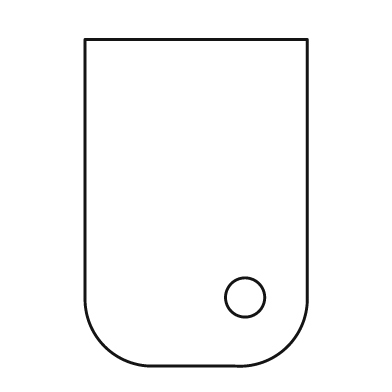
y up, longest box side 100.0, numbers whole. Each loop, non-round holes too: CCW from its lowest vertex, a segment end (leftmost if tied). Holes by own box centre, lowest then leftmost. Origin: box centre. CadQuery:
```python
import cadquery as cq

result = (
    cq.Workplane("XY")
    .moveTo(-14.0, -50.0)
    .lineTo(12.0, -50.0)
    .threePointArc((28.0, -44.0), (34.0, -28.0))
    .lineTo(34.0, 50.0)
    .lineTo(-34.0, 50.0)
    .lineTo(-34.0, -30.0)
    .threePointArc((-28.0, -44.0), (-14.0, -50.0))
    .close()
    .moveTo(15.0, -29.0)
    .circle(6.0)
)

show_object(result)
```